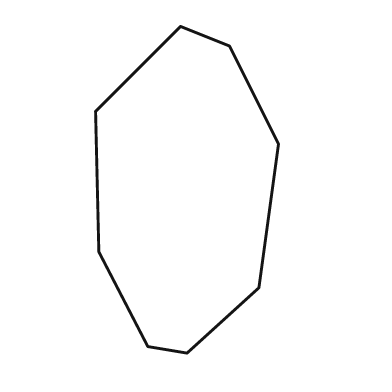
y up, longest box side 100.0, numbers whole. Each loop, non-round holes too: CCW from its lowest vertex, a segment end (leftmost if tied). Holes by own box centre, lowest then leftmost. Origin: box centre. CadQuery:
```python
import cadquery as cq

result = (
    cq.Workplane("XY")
    .moveTo(0.0, -50.0)
    .lineTo(22.0, -30.0)
    .lineTo(28.0, 14.0)
    .lineTo(13.0, 44.0)
    .lineTo(-2.0, 50.0)
    .lineTo(-28.0, 24.0)
    .lineTo(-27.0, -19.0)
    .lineTo(-12.0, -48.0)
    .close()
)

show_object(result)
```